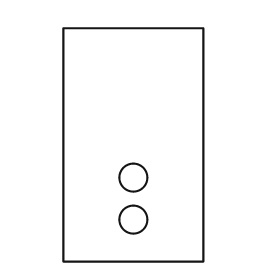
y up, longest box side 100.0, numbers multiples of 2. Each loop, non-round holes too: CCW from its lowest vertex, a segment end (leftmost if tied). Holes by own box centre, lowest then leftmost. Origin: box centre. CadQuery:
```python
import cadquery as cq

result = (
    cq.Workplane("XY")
    .moveTo(-30.0, -50.0)
    .lineTo(30.0, -50.0)
    .lineTo(30.0, 50.0)
    .lineTo(-30.0, 50.0)
    .close()
    .moveTo(0.0, -32.0)
    .circle(6.0)
    .moveTo(0.0, -14.0)
    .circle(6.0)
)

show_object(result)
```